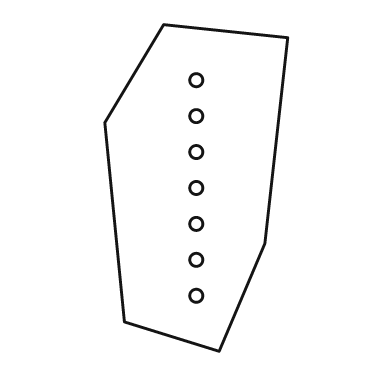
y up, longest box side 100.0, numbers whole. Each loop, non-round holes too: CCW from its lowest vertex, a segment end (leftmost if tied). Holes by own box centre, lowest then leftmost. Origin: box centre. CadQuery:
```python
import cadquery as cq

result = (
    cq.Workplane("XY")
    .moveTo(7.0, -50.0)
    .lineTo(21.0, -17.0)
    .lineTo(28.0, 46.0)
    .lineTo(-10.0, 50.0)
    .lineTo(-28.0, 20.0)
    .lineTo(-22.0, -41.0)
    .close()
    .moveTo(0.0, -33.0)
    .circle(2.0)
    .moveTo(0.0, -22.0)
    .circle(2.0)
    .moveTo(0.0, -11.0)
    .circle(2.0)
    .moveTo(0.0, 0.0)
    .circle(2.0)
    .moveTo(0.0, 11.0)
    .circle(2.0)
    .moveTo(0.0, 22.0)
    .circle(2.0)
    .moveTo(0.0, 33.0)
    .circle(2.0)
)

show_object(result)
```